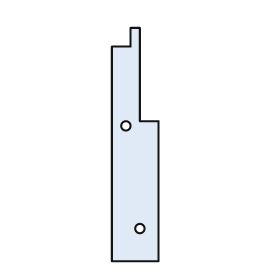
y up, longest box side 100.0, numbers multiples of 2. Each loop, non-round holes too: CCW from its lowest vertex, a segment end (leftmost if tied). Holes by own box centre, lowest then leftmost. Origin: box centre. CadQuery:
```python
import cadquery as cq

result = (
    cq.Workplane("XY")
    .moveTo(-10.0, -50.0)
    .lineTo(10.0, -50.0)
    .lineTo(10.0, 10.0)
    .lineTo(2.0, 10.0)
    .lineTo(2.0, 50.0)
    .lineTo(-2.0, 50.0)
    .lineTo(-2.0, 42.0)
    .lineTo(-10.0, 42.0)
    .close()
    .moveTo(2.0, -36.0)
    .circle(2.0)
    .moveTo(-4.0, 8.0)
    .circle(2.0)
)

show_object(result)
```